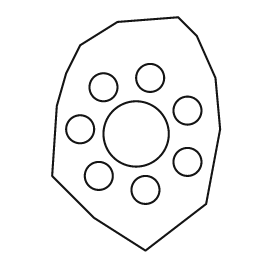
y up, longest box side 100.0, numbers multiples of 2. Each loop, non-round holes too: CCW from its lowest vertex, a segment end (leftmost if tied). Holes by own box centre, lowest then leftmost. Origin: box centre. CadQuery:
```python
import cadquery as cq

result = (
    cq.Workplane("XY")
    .moveTo(4.0, -50.0)
    .lineTo(30.0, -30.0)
    .lineTo(36.0, 2.0)
    .lineTo(34.0, 24.0)
    .lineTo(26.0, 42.0)
    .lineTo(18.0, 50.0)
    .lineTo(-8.0, 48.0)
    .lineTo(-24.0, 38.0)
    .lineTo(-30.0, 26.0)
    .lineTo(-34.0, 12.0)
    .lineTo(-36.0, -18.0)
    .lineTo(-18.0, -36.0)
    .close()
    .moveTo(4.0, -24.0)
    .circle(6.0)
    .moveTo(-16.0, -18.0)
    .circle(6.0)
    .moveTo(22.0, -12.0)
    .circle(6.0)
    .moveTo(0.0, 0.0)
    .circle(14.0)
    .moveTo(-24.0, 2.0)
    .circle(6.0)
    .moveTo(22.0, 10.0)
    .circle(6.0)
    .moveTo(-14.0, 20.0)
    .circle(6.0)
    .moveTo(6.0, 24.0)
    .circle(6.0)
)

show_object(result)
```